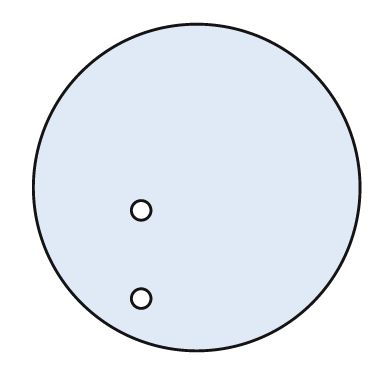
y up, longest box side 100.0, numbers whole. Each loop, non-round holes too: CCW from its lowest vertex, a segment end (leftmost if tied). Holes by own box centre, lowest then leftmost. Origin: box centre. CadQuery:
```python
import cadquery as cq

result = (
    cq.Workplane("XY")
    .moveTo(0.0, 0.0)
    .circle(50.0)
    .moveTo(-17.0, -34.0)
    .circle(3.0)
    .moveTo(-17.0, -7.0)
    .circle(3.0)
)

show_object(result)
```